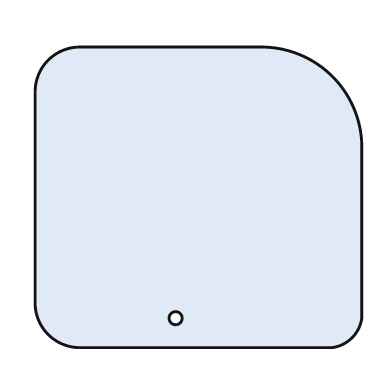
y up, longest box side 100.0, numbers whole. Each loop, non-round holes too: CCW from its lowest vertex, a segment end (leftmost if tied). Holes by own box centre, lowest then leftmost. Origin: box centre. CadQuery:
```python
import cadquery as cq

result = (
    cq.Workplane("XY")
    .moveTo(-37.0, -46.0)
    .lineTo(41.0, -46.0)
    .threePointArc((47.0, -43.0), (50.0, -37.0))
    .lineTo(50.0, 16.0)
    .threePointArc((41.0, 37.0), (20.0, 46.0))
    .lineTo(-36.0, 46.0)
    .threePointArc((-46.0, 42.0), (-50.0, 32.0))
    .lineTo(-50.0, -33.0)
    .threePointArc((-46.0, -42.0), (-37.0, -46.0))
    .close()
    .moveTo(-7.0, -37.0)
    .circle(2.0)
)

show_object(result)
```